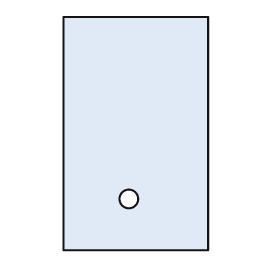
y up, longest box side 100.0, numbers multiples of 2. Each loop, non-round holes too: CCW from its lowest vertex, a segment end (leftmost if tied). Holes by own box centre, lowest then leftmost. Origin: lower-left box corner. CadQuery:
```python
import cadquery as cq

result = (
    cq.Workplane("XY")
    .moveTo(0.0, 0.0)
    .lineTo(62.0, 0.0)
    .lineTo(62.0, 100.0)
    .lineTo(0.0, 100.0)
    .close()
    .moveTo(28.0, 22.0)
    .circle(4.0)
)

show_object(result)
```